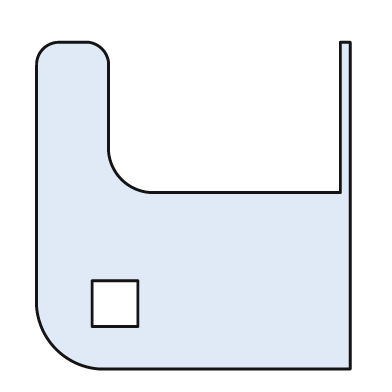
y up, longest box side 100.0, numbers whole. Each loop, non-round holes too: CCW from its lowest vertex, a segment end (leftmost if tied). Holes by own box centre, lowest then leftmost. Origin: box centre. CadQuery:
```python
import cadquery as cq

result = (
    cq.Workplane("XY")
    .moveTo(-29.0, -50.0)
    .lineTo(48.0, -50.0)
    .lineTo(48.0, 50.0)
    .lineTo(45.0, 50.0)
    .lineTo(45.0, 4.0)
    .lineTo(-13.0, 4.0)
    .threePointArc((-22.0, 8.0), (-26.0, 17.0))
    .lineTo(-26.0, 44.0)
    .threePointArc((-28.0, 48.0), (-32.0, 50.0))
    .lineTo(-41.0, 50.0)
    .threePointArc((-46.0, 48.0), (-48.0, 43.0))
    .lineTo(-48.0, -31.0)
    .threePointArc((-42.0, -44.0), (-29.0, -50.0))
    .close()
    .moveTo(-31.0, -37.0)
    .lineTo(-17.0, -37.0)
    .lineTo(-17.0, -23.0)
    .lineTo(-31.0, -23.0)
    .close()
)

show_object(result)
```